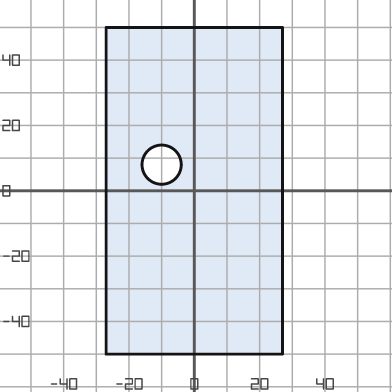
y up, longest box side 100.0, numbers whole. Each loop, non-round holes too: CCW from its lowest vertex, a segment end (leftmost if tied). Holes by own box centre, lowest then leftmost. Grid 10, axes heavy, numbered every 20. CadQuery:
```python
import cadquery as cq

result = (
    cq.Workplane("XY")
    .moveTo(-27.0, -50.0)
    .lineTo(27.0, -50.0)
    .lineTo(27.0, 50.0)
    .lineTo(-27.0, 50.0)
    .close()
    .moveTo(-10.0, 8.0)
    .circle(6.0)
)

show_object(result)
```